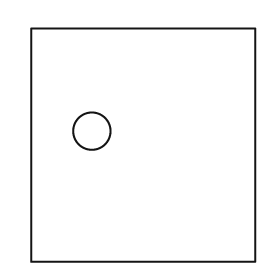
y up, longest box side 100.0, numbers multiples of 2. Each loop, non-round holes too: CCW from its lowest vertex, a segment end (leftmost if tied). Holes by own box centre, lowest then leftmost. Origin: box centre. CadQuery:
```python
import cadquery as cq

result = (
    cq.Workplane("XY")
    .moveTo(-48.0, -50.0)
    .lineTo(48.0, -50.0)
    .lineTo(48.0, 50.0)
    .lineTo(-48.0, 50.0)
    .close()
    .moveTo(-22.0, 6.0)
    .circle(8.0)
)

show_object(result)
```